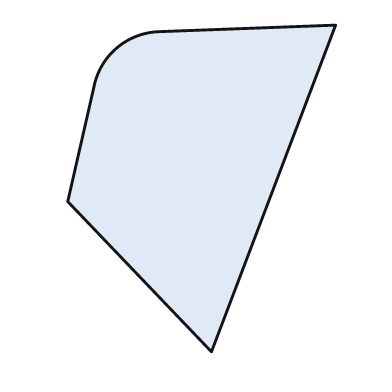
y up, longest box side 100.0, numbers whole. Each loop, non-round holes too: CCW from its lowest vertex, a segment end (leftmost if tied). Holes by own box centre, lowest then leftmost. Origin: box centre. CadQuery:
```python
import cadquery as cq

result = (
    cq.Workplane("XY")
    .moveTo(3.0, -50.0)
    .lineTo(41.0, 50.0)
    .lineTo(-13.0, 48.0)
    .threePointArc((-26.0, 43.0), (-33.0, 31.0))
    .lineTo(-41.0, -4.0)
    .close()
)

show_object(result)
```